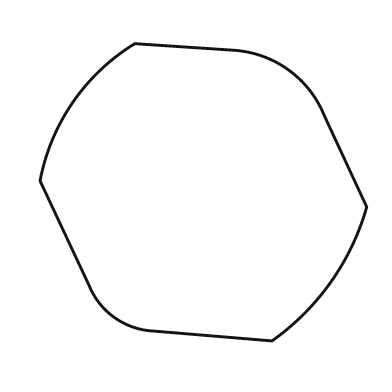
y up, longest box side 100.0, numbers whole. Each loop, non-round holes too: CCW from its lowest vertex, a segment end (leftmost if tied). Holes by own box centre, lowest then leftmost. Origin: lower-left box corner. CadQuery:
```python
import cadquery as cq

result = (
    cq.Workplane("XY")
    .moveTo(71.0, 0.0)
    .threePointArc((89.0, 18.0), (100.0, 41.0))
    .lineTo(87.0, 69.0)
    .threePointArc((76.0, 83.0), (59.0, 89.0))
    .lineTo(29.0, 91.0)
    .threePointArc((10.0, 73.0), (0.0, 49.0))
    .lineTo(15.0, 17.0)
    .threePointArc((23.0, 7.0), (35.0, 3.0))
    .close()
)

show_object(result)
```